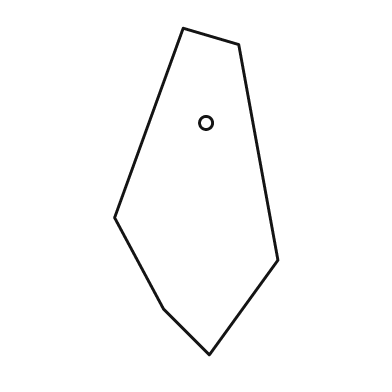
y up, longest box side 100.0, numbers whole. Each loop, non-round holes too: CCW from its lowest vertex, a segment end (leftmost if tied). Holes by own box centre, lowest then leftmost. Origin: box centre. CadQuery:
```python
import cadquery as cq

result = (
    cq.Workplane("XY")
    .moveTo(4.0, -50.0)
    .lineTo(25.0, -21.0)
    .lineTo(13.0, 45.0)
    .lineTo(-4.0, 50.0)
    .lineTo(-25.0, -8.0)
    .lineTo(-10.0, -36.0)
    .close()
    .moveTo(3.0, 21.0)
    .circle(2.0)
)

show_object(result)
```